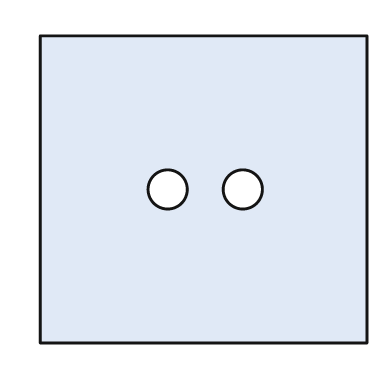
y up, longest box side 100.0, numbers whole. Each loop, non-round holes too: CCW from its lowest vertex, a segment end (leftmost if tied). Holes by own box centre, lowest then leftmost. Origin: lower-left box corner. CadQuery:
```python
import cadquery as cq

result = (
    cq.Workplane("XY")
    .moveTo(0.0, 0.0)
    .lineTo(100.0, 0.0)
    .lineTo(100.0, 94.0)
    .lineTo(0.0, 94.0)
    .close()
    .moveTo(39.0, 47.0)
    .circle(6.0)
    .moveTo(62.0, 47.0)
    .circle(6.0)
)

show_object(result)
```